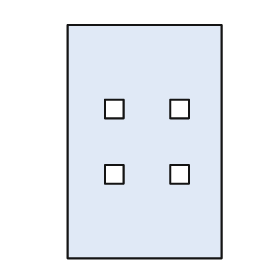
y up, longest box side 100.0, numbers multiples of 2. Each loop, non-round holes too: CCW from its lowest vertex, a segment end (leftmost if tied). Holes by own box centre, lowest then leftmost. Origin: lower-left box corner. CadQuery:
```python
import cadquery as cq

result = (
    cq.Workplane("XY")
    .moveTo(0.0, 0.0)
    .lineTo(66.0, 0.0)
    .lineTo(66.0, 100.0)
    .lineTo(0.0, 100.0)
    .close()
    .moveTo(16.0, 32.0)
    .lineTo(24.0, 32.0)
    .lineTo(24.0, 40.0)
    .lineTo(16.0, 40.0)
    .close()
    .moveTo(44.0, 32.0)
    .lineTo(52.0, 32.0)
    .lineTo(52.0, 40.0)
    .lineTo(44.0, 40.0)
    .close()
    .moveTo(16.0, 60.0)
    .lineTo(24.0, 60.0)
    .lineTo(24.0, 68.0)
    .lineTo(16.0, 68.0)
    .close()
    .moveTo(44.0, 60.0)
    .lineTo(52.0, 60.0)
    .lineTo(52.0, 68.0)
    .lineTo(44.0, 68.0)
    .close()
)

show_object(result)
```